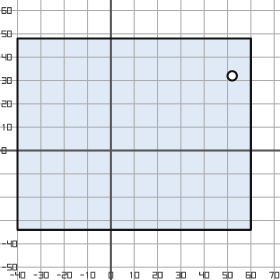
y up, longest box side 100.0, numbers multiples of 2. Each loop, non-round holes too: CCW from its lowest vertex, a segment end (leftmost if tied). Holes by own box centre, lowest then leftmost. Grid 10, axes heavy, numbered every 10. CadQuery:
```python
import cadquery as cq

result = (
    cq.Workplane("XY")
    .moveTo(-40.0, -34.0)
    .lineTo(60.0, -34.0)
    .lineTo(60.0, 48.0)
    .lineTo(-40.0, 48.0)
    .close()
    .moveTo(52.0, 32.0)
    .circle(2.0)
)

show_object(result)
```